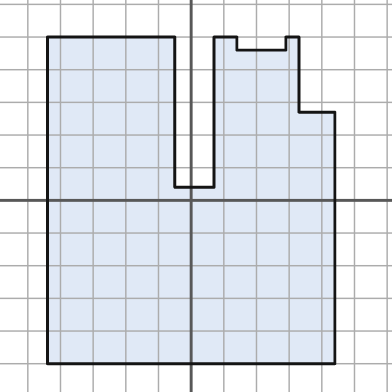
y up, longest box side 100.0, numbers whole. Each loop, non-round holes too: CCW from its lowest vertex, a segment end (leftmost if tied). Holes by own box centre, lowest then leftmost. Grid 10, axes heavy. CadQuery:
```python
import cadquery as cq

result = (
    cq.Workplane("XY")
    .moveTo(-44.0, -50.0)
    .lineTo(44.0, -50.0)
    .lineTo(44.0, 27.0)
    .lineTo(33.0, 27.0)
    .lineTo(33.0, 50.0)
    .lineTo(29.0, 50.0)
    .lineTo(29.0, 46.0)
    .lineTo(14.0, 46.0)
    .lineTo(14.0, 50.0)
    .lineTo(7.0, 50.0)
    .lineTo(7.0, 4.0)
    .lineTo(-5.0, 4.0)
    .lineTo(-5.0, 50.0)
    .lineTo(-44.0, 50.0)
    .close()
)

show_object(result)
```